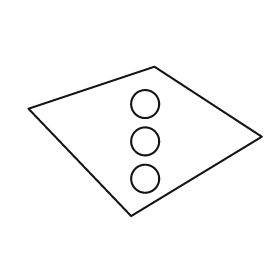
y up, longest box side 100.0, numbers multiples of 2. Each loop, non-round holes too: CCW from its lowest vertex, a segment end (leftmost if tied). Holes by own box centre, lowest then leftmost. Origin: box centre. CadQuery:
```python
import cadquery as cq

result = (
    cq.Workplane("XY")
    .moveTo(-6.0, -32.0)
    .lineTo(50.0, 2.0)
    .lineTo(4.0, 32.0)
    .lineTo(-50.0, 14.0)
    .close()
    .moveTo(0.0, -16.0)
    .circle(6.0)
    .moveTo(0.0, 0.0)
    .circle(6.0)
    .moveTo(0.0, 16.0)
    .circle(6.0)
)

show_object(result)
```